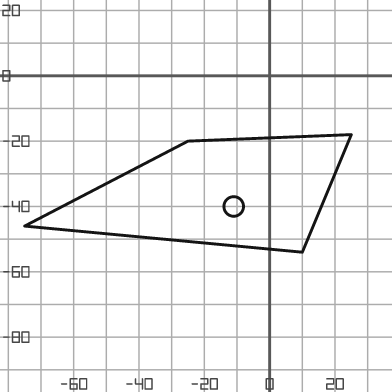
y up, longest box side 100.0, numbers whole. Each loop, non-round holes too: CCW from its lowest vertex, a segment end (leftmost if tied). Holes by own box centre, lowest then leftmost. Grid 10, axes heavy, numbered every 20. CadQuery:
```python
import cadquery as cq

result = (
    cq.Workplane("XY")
    .moveTo(10.0, -54.0)
    .lineTo(25.0, -18.0)
    .lineTo(-25.0, -20.0)
    .lineTo(-75.0, -46.0)
    .close()
    .moveTo(-11.0, -40.0)
    .circle(3.0)
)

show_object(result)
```